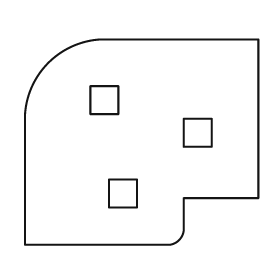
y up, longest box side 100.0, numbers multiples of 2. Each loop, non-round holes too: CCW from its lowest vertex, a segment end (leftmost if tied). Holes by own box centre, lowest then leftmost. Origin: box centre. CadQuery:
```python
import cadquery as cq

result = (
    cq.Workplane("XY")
    .moveTo(-50.0, -44.0)
    .lineTo(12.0, -44.0)
    .threePointArc((16.0, -42.0), (18.0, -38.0))
    .lineTo(18.0, -24.0)
    .lineTo(50.0, -24.0)
    .lineTo(50.0, 44.0)
    .lineTo(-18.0, 44.0)
    .threePointArc((-40.0, 34.0), (-50.0, 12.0))
    .close()
    .moveTo(-14.0, -28.0)
    .lineTo(-2.0, -28.0)
    .lineTo(-2.0, -16.0)
    .lineTo(-14.0, -16.0)
    .close()
    .moveTo(18.0, -2.0)
    .lineTo(30.0, -2.0)
    .lineTo(30.0, 10.0)
    .lineTo(18.0, 10.0)
    .close()
    .moveTo(-22.0, 12.0)
    .lineTo(-10.0, 12.0)
    .lineTo(-10.0, 24.0)
    .lineTo(-22.0, 24.0)
    .close()
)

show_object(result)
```